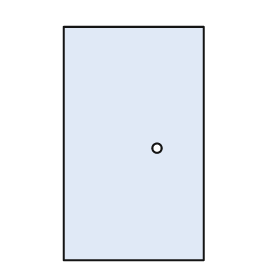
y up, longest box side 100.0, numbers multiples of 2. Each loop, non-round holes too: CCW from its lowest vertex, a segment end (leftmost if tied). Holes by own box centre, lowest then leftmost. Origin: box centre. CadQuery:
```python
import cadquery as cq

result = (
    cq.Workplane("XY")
    .moveTo(-30.0, -50.0)
    .lineTo(30.0, -50.0)
    .lineTo(30.0, 50.0)
    .lineTo(-30.0, 50.0)
    .close()
    .moveTo(10.0, -2.0)
    .circle(2.0)
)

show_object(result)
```